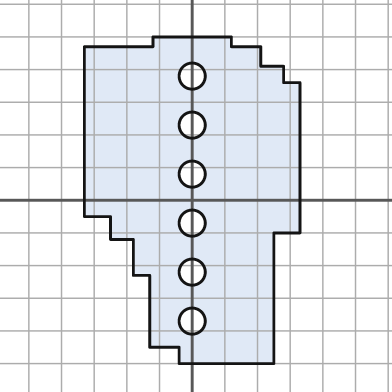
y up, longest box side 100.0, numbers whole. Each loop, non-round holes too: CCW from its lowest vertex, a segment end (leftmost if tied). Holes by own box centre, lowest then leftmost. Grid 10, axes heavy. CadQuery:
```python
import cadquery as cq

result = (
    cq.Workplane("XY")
    .moveTo(-4.0, -50.0)
    .lineTo(25.0, -50.0)
    .lineTo(25.0, -10.0)
    .lineTo(33.0, -10.0)
    .lineTo(33.0, 36.0)
    .lineTo(28.0, 36.0)
    .lineTo(28.0, 41.0)
    .lineTo(21.0, 41.0)
    .lineTo(21.0, 47.0)
    .lineTo(12.0, 47.0)
    .lineTo(12.0, 50.0)
    .lineTo(-12.0, 50.0)
    .lineTo(-12.0, 47.0)
    .lineTo(-33.0, 47.0)
    .lineTo(-33.0, -5.0)
    .lineTo(-25.0, -5.0)
    .lineTo(-25.0, -12.0)
    .lineTo(-18.0, -12.0)
    .lineTo(-18.0, -23.0)
    .lineTo(-13.0, -23.0)
    .lineTo(-13.0, -45.0)
    .lineTo(-4.0, -45.0)
    .close()
    .moveTo(0.0, -37.0)
    .circle(4.0)
    .moveTo(0.0, -22.0)
    .circle(4.0)
    .moveTo(0.0, -7.0)
    .circle(4.0)
    .moveTo(0.0, 8.0)
    .circle(4.0)
    .moveTo(0.0, 23.0)
    .circle(4.0)
    .moveTo(0.0, 38.0)
    .circle(4.0)
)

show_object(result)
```